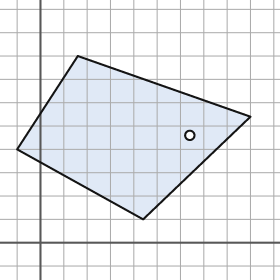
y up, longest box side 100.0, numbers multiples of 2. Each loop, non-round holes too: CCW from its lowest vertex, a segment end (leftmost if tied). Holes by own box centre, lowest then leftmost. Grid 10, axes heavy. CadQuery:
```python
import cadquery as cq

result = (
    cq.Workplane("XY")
    .moveTo(44.0, 10.0)
    .lineTo(90.0, 54.0)
    .lineTo(16.0, 80.0)
    .lineTo(-10.0, 40.0)
    .close()
    .moveTo(64.0, 46.0)
    .circle(2.0)
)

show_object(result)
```